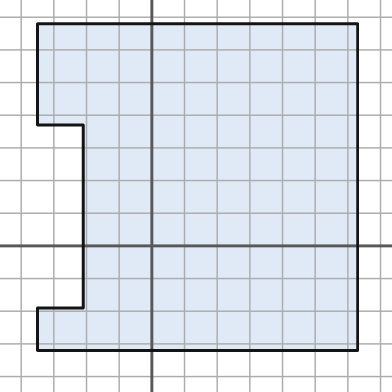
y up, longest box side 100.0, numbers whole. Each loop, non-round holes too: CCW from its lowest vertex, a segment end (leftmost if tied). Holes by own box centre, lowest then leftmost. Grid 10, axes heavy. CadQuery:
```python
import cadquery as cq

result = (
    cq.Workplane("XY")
    .moveTo(-35.0, -32.0)
    .lineTo(63.0, -32.0)
    .lineTo(63.0, 68.0)
    .lineTo(-35.0, 68.0)
    .lineTo(-35.0, 37.0)
    .lineTo(-21.0, 37.0)
    .lineTo(-21.0, -19.0)
    .lineTo(-35.0, -19.0)
    .close()
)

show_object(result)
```